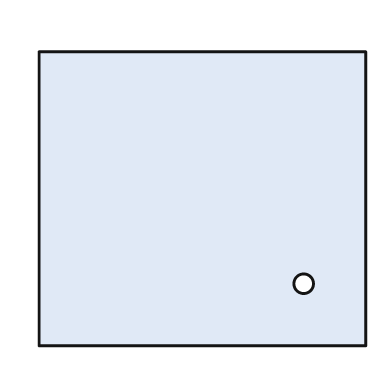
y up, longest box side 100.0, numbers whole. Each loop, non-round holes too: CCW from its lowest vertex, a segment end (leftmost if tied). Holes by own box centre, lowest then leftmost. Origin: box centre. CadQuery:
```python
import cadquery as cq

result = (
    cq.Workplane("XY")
    .moveTo(-50.0, -45.0)
    .lineTo(50.0, -45.0)
    .lineTo(50.0, 45.0)
    .lineTo(-50.0, 45.0)
    .close()
    .moveTo(31.0, -26.0)
    .circle(3.0)
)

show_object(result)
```